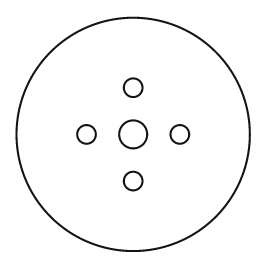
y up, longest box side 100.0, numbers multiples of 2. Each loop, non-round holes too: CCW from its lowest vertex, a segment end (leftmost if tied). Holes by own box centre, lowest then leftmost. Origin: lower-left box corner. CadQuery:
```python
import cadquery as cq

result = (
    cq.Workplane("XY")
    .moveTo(50.0, 50.0)
    .circle(50.0)
    .moveTo(50.0, 30.0)
    .circle(4.0)
    .moveTo(30.0, 50.0)
    .circle(4.0)
    .moveTo(50.0, 50.0)
    .circle(6.0)
    .moveTo(70.0, 50.0)
    .circle(4.0)
    .moveTo(50.0, 70.0)
    .circle(4.0)
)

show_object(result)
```